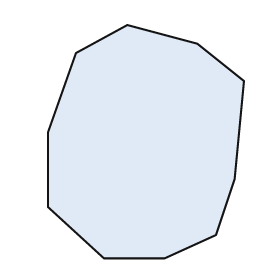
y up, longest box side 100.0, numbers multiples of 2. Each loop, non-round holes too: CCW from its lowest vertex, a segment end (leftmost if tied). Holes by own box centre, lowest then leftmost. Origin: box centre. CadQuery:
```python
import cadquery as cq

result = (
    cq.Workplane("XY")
    .moveTo(-18.0, -50.0)
    .lineTo(8.0, -50.0)
    .lineTo(30.0, -40.0)
    .lineTo(38.0, -16.0)
    .lineTo(42.0, 26.0)
    .lineTo(22.0, 42.0)
    .lineTo(-8.0, 50.0)
    .lineTo(-30.0, 38.0)
    .lineTo(-42.0, 4.0)
    .lineTo(-42.0, -28.0)
    .close()
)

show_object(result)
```